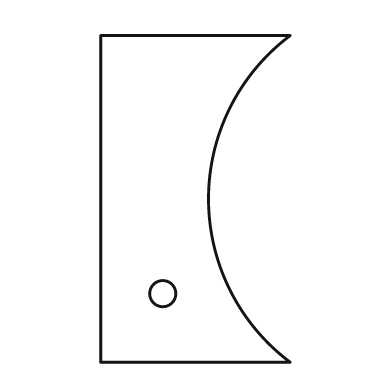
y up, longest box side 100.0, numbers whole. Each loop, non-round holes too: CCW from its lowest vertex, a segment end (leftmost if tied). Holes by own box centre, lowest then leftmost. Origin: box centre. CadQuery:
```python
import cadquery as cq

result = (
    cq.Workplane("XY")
    .moveTo(-29.0, -50.0)
    .lineTo(29.0, -50.0)
    .threePointArc((4.0, 0.0), (29.0, 50.0))
    .lineTo(-29.0, 50.0)
    .close()
    .moveTo(-10.0, -29.0)
    .circle(4.0)
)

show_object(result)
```